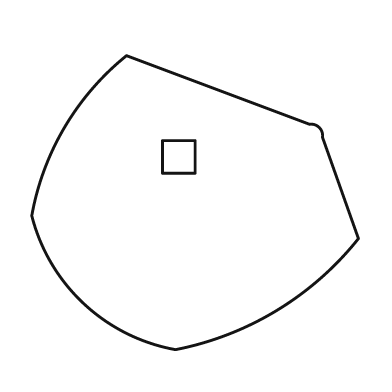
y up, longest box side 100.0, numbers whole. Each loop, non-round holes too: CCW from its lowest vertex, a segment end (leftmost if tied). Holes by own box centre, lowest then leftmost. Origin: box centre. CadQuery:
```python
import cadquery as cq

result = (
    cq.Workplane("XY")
    .moveTo(-6.0, -45.0)
    .threePointArc((25.0, -33.0), (50.0, -11.0))
    .lineTo(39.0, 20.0)
    .threePointArc((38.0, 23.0), (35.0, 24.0))
    .lineTo(-21.0, 45.0)
    .threePointArc((-40.0, 23.0), (-50.0, -4.0))
    .threePointArc((-34.0, -31.0), (-6.0, -45.0))
    .close()
    .moveTo(-10.0, 9.0)
    .lineTo(0.0, 9.0)
    .lineTo(0.0, 19.0)
    .lineTo(-10.0, 19.0)
    .close()
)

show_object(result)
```